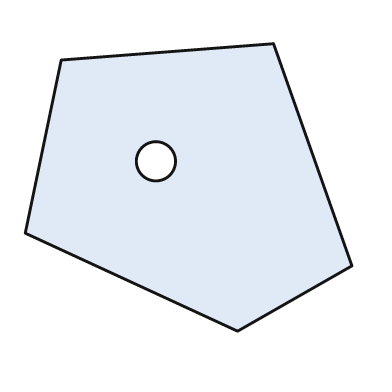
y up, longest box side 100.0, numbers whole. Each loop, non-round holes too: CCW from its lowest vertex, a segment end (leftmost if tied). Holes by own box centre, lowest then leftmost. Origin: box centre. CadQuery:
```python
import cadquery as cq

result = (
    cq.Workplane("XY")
    .moveTo(15.0, -44.0)
    .lineTo(50.0, -24.0)
    .lineTo(26.0, 44.0)
    .lineTo(-39.0, 39.0)
    .lineTo(-50.0, -14.0)
    .close()
    .moveTo(-10.0, 8.0)
    .circle(6.0)
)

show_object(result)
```